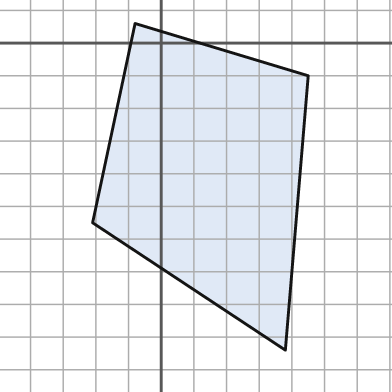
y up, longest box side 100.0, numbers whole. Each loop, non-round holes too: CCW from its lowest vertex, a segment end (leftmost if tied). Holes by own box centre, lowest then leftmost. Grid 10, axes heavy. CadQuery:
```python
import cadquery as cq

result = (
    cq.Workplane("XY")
    .moveTo(38.0, -94.0)
    .lineTo(45.0, -10.0)
    .lineTo(-8.0, 6.0)
    .lineTo(-21.0, -55.0)
    .close()
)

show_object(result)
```